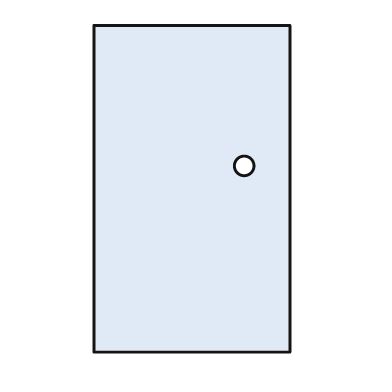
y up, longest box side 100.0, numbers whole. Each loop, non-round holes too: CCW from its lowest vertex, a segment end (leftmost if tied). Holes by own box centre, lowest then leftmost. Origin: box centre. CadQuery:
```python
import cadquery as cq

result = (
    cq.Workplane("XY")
    .moveTo(-30.0, -50.0)
    .lineTo(30.0, -50.0)
    .lineTo(30.0, 50.0)
    .lineTo(-30.0, 50.0)
    .close()
    .moveTo(16.0, 7.0)
    .circle(3.0)
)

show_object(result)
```